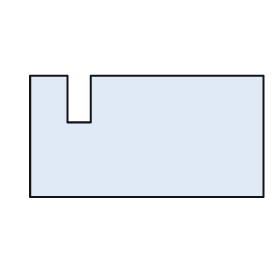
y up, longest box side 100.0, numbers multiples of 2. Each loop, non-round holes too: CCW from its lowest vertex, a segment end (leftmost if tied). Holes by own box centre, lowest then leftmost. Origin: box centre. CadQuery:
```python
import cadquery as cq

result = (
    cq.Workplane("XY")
    .moveTo(-50.0, -26.0)
    .lineTo(50.0, -26.0)
    .lineTo(50.0, 26.0)
    .lineTo(-24.0, 26.0)
    .lineTo(-24.0, 6.0)
    .lineTo(-34.0, 6.0)
    .lineTo(-34.0, 26.0)
    .lineTo(-50.0, 26.0)
    .close()
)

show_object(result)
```